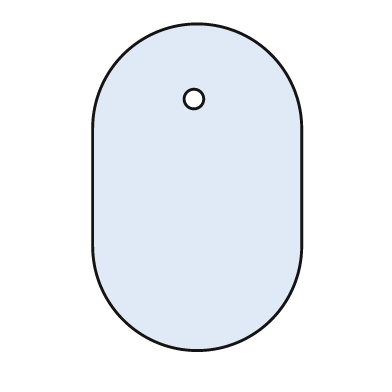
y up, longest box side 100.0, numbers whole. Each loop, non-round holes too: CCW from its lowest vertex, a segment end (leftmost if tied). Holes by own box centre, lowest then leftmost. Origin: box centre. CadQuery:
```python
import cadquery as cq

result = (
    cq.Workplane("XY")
    .moveTo(-32.0, -18.0)
    .threePointArc((0.0, -50.0), (32.0, -18.0))
    .lineTo(32.0, 18.0)
    .threePointArc((0.0, 50.0), (-32.0, 18.0))
    .close()
    .moveTo(-1.0, 27.0)
    .circle(3.0)
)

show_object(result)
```